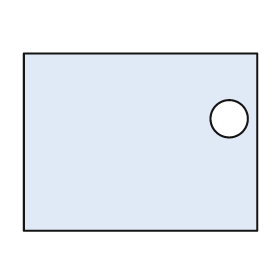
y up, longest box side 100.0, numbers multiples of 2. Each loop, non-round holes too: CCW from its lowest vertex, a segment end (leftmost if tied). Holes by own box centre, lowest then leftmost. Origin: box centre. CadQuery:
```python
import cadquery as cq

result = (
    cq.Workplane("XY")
    .moveTo(-50.0, -38.0)
    .lineTo(50.0, -38.0)
    .lineTo(50.0, 38.0)
    .lineTo(-50.0, 38.0)
    .close()
    .moveTo(38.0, 10.0)
    .circle(8.0)
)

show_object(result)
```